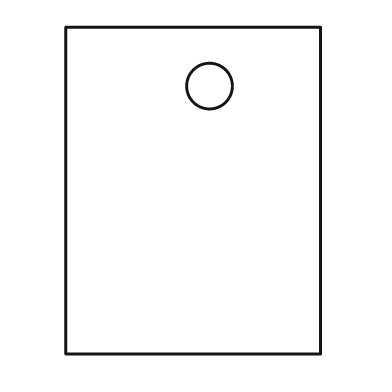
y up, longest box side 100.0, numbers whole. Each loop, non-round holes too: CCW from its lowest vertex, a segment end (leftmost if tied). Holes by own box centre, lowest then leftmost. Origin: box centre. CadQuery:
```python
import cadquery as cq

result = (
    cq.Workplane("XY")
    .moveTo(-39.0, -50.0)
    .lineTo(39.0, -50.0)
    .lineTo(39.0, 50.0)
    .lineTo(-39.0, 50.0)
    .close()
    .moveTo(5.0, 32.0)
    .circle(7.0)
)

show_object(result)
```